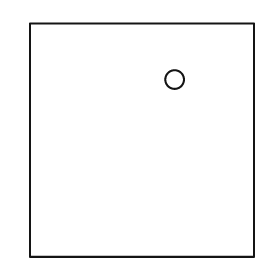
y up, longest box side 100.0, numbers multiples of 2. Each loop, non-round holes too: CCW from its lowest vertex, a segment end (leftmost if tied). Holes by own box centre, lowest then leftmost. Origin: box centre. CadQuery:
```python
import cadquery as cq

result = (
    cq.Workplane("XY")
    .moveTo(-48.0, -50.0)
    .lineTo(48.0, -50.0)
    .lineTo(48.0, 50.0)
    .lineTo(-48.0, 50.0)
    .close()
    .moveTo(14.0, 26.0)
    .circle(4.0)
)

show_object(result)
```